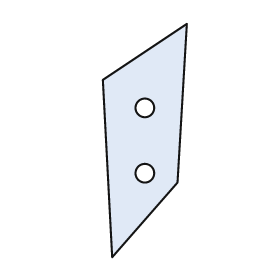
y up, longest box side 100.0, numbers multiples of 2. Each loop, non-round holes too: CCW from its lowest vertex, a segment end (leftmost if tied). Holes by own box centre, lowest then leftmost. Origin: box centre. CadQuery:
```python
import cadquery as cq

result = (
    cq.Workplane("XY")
    .moveTo(-14.0, -50.0)
    .lineTo(14.0, -18.0)
    .lineTo(18.0, 50.0)
    .lineTo(-18.0, 26.0)
    .close()
    .moveTo(0.0, -14.0)
    .circle(4.0)
    .moveTo(0.0, 14.0)
    .circle(4.0)
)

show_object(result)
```